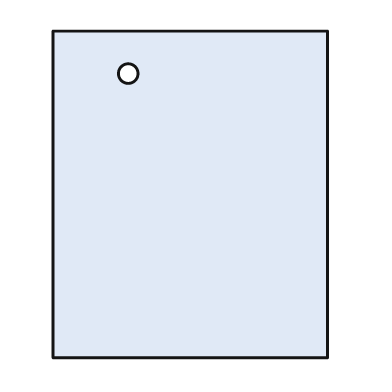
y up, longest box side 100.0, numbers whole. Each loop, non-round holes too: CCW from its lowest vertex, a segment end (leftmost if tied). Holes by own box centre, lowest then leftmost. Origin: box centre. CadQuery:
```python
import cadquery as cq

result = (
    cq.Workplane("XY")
    .moveTo(-42.0, -50.0)
    .lineTo(42.0, -50.0)
    .lineTo(42.0, 50.0)
    .lineTo(-42.0, 50.0)
    .close()
    .moveTo(-19.0, 37.0)
    .circle(3.0)
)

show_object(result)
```